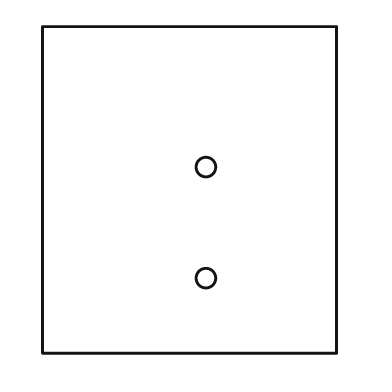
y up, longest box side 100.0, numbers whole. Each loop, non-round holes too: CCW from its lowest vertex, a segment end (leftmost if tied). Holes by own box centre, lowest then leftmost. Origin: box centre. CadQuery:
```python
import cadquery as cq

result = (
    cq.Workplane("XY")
    .moveTo(-45.0, -50.0)
    .lineTo(45.0, -50.0)
    .lineTo(45.0, 50.0)
    .lineTo(-45.0, 50.0)
    .close()
    .moveTo(5.0, -27.0)
    .circle(3.0)
    .moveTo(5.0, 7.0)
    .circle(3.0)
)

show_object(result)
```